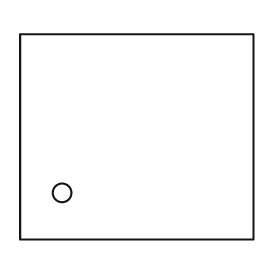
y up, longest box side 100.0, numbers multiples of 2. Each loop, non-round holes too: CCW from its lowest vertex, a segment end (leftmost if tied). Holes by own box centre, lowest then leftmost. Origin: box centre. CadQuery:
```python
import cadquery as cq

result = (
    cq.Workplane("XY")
    .moveTo(-50.0, -44.0)
    .lineTo(50.0, -44.0)
    .lineTo(50.0, 44.0)
    .lineTo(-50.0, 44.0)
    .close()
    .moveTo(-32.0, -24.0)
    .circle(4.0)
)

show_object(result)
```